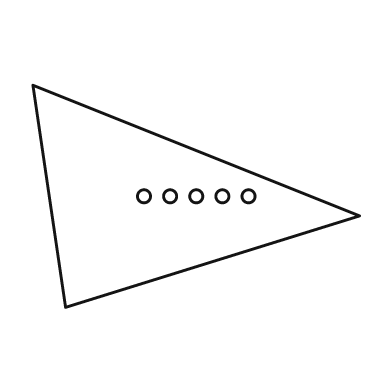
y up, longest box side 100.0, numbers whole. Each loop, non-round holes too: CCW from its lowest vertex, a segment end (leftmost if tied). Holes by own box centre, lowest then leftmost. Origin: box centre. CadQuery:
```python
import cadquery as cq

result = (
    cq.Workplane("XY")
    .moveTo(-40.0, -34.0)
    .lineTo(50.0, -6.0)
    .lineTo(-50.0, 34.0)
    .close()
    .moveTo(-16.0, 0.0)
    .circle(2.0)
    .moveTo(-8.0, 0.0)
    .circle(2.0)
    .moveTo(0.0, 0.0)
    .circle(2.0)
    .moveTo(8.0, 0.0)
    .circle(2.0)
    .moveTo(16.0, 0.0)
    .circle(2.0)
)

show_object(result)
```